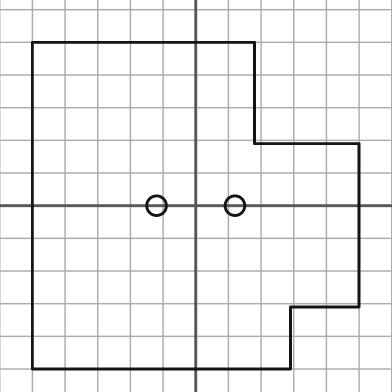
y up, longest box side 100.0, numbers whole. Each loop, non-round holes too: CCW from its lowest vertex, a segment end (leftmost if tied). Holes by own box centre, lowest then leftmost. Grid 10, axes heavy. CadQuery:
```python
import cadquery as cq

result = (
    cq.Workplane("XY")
    .moveTo(-50.0, -50.0)
    .lineTo(29.0, -50.0)
    .lineTo(29.0, -31.0)
    .lineTo(50.0, -31.0)
    .lineTo(50.0, 19.0)
    .lineTo(18.0, 19.0)
    .lineTo(18.0, 50.0)
    .lineTo(-50.0, 50.0)
    .close()
    .moveTo(-12.0, 0.0)
    .circle(3.0)
    .moveTo(12.0, 0.0)
    .circle(3.0)
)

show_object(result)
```